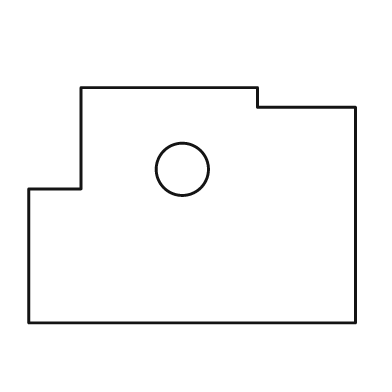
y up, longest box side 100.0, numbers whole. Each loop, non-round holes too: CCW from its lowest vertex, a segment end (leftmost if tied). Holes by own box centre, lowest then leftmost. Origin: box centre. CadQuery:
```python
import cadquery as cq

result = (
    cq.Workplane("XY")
    .moveTo(-50.0, -36.0)
    .lineTo(50.0, -36.0)
    .lineTo(50.0, 30.0)
    .lineTo(20.0, 30.0)
    .lineTo(20.0, 36.0)
    .lineTo(-34.0, 36.0)
    .lineTo(-34.0, 5.0)
    .lineTo(-50.0, 5.0)
    .close()
    .moveTo(-3.0, 11.0)
    .circle(8.0)
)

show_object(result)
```